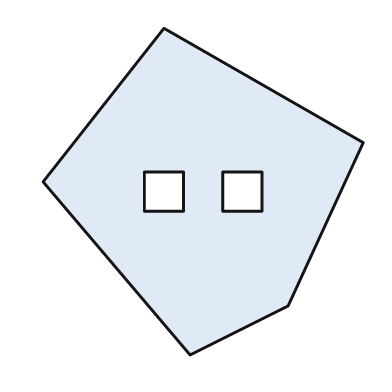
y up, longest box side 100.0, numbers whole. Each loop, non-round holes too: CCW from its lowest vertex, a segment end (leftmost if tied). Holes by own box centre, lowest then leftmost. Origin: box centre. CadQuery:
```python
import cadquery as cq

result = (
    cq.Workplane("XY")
    .moveTo(-4.0, -50.0)
    .lineTo(26.0, -35.0)
    .lineTo(49.0, 15.0)
    .lineTo(-12.0, 50.0)
    .lineTo(-49.0, 3.0)
    .close()
    .moveTo(-18.0, -6.0)
    .lineTo(-6.0, -6.0)
    .lineTo(-6.0, 6.0)
    .lineTo(-18.0, 6.0)
    .close()
    .moveTo(6.0, -6.0)
    .lineTo(18.0, -6.0)
    .lineTo(18.0, 6.0)
    .lineTo(6.0, 6.0)
    .close()
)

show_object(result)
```